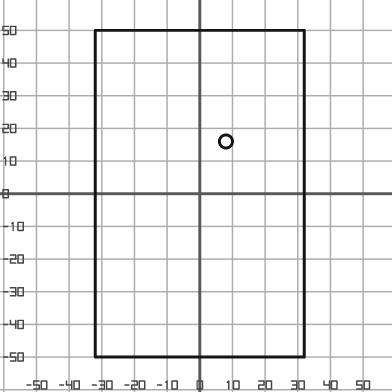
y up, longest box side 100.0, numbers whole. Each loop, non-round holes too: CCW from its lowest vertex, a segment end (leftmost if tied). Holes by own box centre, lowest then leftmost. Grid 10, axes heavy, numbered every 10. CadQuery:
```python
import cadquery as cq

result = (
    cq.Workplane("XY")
    .moveTo(-32.0, -50.0)
    .lineTo(32.0, -50.0)
    .lineTo(32.0, 50.0)
    .lineTo(-32.0, 50.0)
    .close()
    .moveTo(8.0, 16.0)
    .circle(2.0)
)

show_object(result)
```